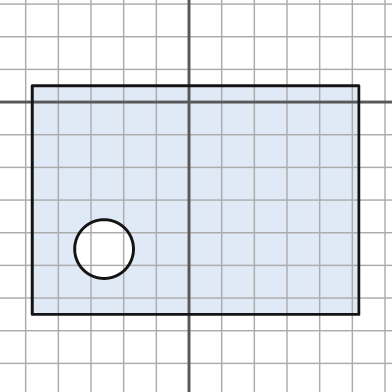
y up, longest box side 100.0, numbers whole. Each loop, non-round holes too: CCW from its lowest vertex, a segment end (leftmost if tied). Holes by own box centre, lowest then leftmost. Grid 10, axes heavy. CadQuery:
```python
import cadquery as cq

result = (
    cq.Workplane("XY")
    .moveTo(-48.0, -65.0)
    .lineTo(52.0, -65.0)
    .lineTo(52.0, 5.0)
    .lineTo(-48.0, 5.0)
    .close()
    .moveTo(-26.0, -45.0)
    .circle(9.0)
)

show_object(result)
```